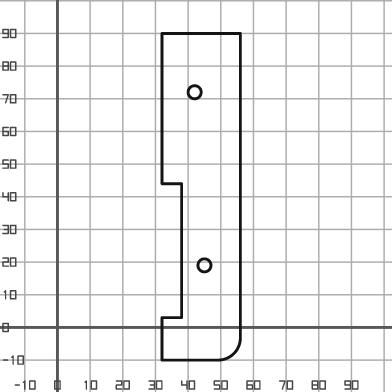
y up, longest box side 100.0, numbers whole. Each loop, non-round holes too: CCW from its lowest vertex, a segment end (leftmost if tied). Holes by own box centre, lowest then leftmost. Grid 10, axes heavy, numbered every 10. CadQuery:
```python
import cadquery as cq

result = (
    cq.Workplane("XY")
    .moveTo(32.0, -10.0)
    .lineTo(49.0, -10.0)
    .threePointArc((54.0, -8.0), (56.0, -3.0))
    .lineTo(56.0, 90.0)
    .lineTo(32.0, 90.0)
    .lineTo(32.0, 44.0)
    .lineTo(38.0, 44.0)
    .lineTo(38.0, 3.0)
    .lineTo(32.0, 3.0)
    .close()
    .moveTo(45.0, 19.0)
    .circle(2.0)
    .moveTo(42.0, 72.0)
    .circle(2.0)
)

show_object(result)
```